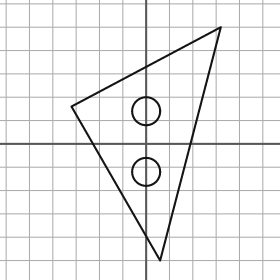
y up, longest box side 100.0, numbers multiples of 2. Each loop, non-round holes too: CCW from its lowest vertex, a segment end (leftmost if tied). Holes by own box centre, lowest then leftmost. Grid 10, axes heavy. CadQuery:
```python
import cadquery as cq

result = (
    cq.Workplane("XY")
    .moveTo(6.0, -50.0)
    .lineTo(32.0, 50.0)
    .lineTo(-32.0, 16.0)
    .close()
    .moveTo(0.0, -12.0)
    .circle(6.0)
    .moveTo(0.0, 14.0)
    .circle(6.0)
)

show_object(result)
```